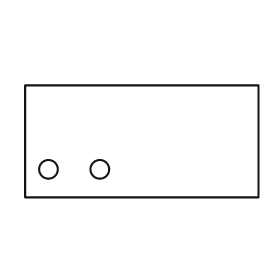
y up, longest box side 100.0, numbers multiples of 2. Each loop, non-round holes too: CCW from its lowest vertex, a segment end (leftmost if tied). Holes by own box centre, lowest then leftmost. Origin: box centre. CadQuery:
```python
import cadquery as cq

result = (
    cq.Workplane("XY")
    .moveTo(-50.0, -24.0)
    .lineTo(50.0, -24.0)
    .lineTo(50.0, 24.0)
    .lineTo(-50.0, 24.0)
    .close()
    .moveTo(-40.0, -12.0)
    .circle(4.0)
    .moveTo(-18.0, -12.0)
    .circle(4.0)
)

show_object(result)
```